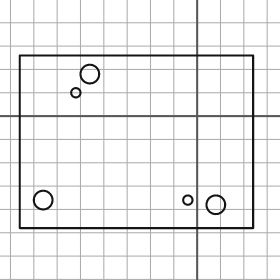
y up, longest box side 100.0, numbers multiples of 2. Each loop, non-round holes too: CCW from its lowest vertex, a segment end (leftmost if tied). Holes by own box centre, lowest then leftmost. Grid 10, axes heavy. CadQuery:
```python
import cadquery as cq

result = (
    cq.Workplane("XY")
    .moveTo(-76.0, -48.0)
    .lineTo(24.0, -48.0)
    .lineTo(24.0, 26.0)
    .lineTo(-76.0, 26.0)
    .close()
    .moveTo(8.0, -38.0)
    .circle(4.0)
    .moveTo(-66.0, -36.0)
    .circle(4.0)
    .moveTo(-4.0, -36.0)
    .circle(2.0)
    .moveTo(-52.0, 10.0)
    .circle(2.0)
    .moveTo(-46.0, 18.0)
    .circle(4.0)
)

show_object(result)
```